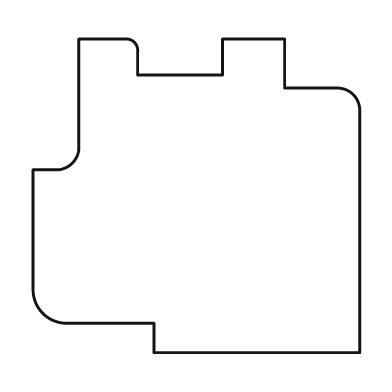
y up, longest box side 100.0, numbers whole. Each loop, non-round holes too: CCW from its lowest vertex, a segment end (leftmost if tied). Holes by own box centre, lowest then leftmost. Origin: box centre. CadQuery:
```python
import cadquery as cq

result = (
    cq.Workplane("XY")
    .moveTo(-13.0, -48.0)
    .lineTo(50.0, -48.0)
    .lineTo(50.0, 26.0)
    .threePointArc((48.0, 31.0), (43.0, 33.0))
    .lineTo(27.0, 33.0)
    .lineTo(27.0, 48.0)
    .lineTo(8.0, 48.0)
    .lineTo(8.0, 37.0)
    .lineTo(-18.0, 37.0)
    .lineTo(-18.0, 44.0)
    .threePointArc((-19.0, 47.0), (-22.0, 48.0))
    .lineTo(-36.0, 48.0)
    .lineTo(-36.0, 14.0)
    .threePointArc((-38.0, 10.0), (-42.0, 8.0))
    .lineTo(-50.0, 8.0)
    .lineTo(-50.0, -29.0)
    .threePointArc((-47.0, -36.0), (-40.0, -39.0))
    .lineTo(-13.0, -39.0)
    .close()
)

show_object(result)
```